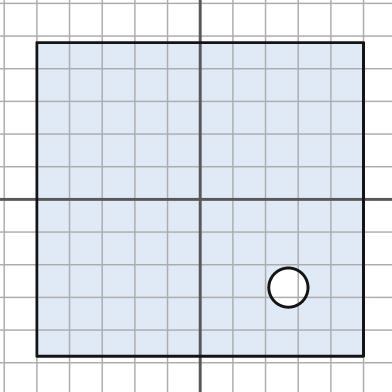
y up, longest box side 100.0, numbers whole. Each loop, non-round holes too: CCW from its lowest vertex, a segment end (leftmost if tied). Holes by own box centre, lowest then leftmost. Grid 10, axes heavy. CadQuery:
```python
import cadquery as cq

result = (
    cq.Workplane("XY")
    .moveTo(-50.0, -48.0)
    .lineTo(50.0, -48.0)
    .lineTo(50.0, 48.0)
    .lineTo(-50.0, 48.0)
    .close()
    .moveTo(27.0, -27.0)
    .circle(6.0)
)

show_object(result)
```